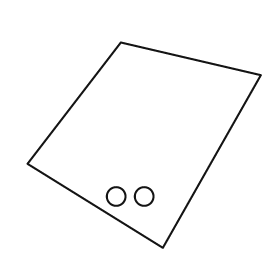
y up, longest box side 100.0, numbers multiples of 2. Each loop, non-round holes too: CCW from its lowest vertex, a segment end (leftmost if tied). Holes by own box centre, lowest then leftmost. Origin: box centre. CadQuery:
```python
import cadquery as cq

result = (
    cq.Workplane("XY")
    .moveTo(8.0, -44.0)
    .lineTo(50.0, 30.0)
    .lineTo(-10.0, 44.0)
    .lineTo(-50.0, -8.0)
    .close()
    .moveTo(-12.0, -22.0)
    .circle(4.0)
    .moveTo(0.0, -22.0)
    .circle(4.0)
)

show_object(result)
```